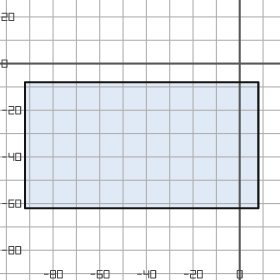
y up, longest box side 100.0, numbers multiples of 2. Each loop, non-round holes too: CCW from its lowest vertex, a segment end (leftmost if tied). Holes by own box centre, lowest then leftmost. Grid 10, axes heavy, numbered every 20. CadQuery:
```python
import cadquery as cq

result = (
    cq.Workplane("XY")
    .moveTo(-92.0, -62.0)
    .lineTo(8.0, -62.0)
    .lineTo(8.0, -8.0)
    .lineTo(-92.0, -8.0)
    .close()
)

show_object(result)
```